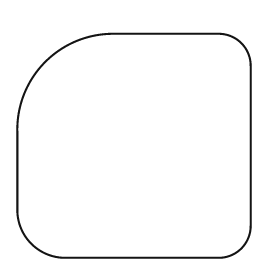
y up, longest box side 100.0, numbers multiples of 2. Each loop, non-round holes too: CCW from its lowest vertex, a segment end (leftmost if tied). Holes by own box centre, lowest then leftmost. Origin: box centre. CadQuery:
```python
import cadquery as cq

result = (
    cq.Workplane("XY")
    .moveTo(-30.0, -48.0)
    .lineTo(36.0, -48.0)
    .threePointArc((46.0, -44.0), (50.0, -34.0))
    .lineTo(50.0, 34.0)
    .threePointArc((46.0, 44.0), (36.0, 48.0))
    .lineTo(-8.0, 48.0)
    .threePointArc((-38.0, 36.0), (-50.0, 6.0))
    .lineTo(-50.0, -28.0)
    .threePointArc((-44.0, -42.0), (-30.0, -48.0))
    .close()
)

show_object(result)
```